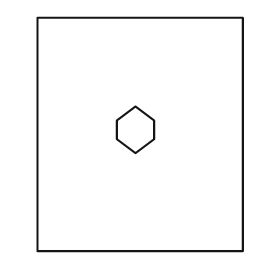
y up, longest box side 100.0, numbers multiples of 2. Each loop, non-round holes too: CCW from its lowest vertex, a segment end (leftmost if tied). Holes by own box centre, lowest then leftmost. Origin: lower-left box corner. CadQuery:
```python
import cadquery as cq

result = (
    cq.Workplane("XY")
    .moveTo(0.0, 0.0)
    .lineTo(88.0, 0.0)
    .lineTo(88.0, 100.0)
    .lineTo(0.0, 100.0)
    .close()
    .moveTo(42.0, 42.0)
    .lineTo(50.0, 48.0)
    .lineTo(50.0, 56.0)
    .lineTo(42.0, 62.0)
    .lineTo(34.0, 56.0)
    .lineTo(34.0, 48.0)
    .close()
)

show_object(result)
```